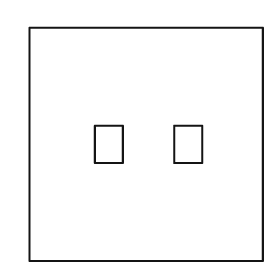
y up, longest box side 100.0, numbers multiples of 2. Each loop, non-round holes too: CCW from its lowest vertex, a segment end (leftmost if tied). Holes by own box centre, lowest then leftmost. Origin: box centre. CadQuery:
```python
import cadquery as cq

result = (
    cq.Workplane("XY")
    .moveTo(-50.0, -50.0)
    .lineTo(50.0, -50.0)
    .lineTo(50.0, 50.0)
    .lineTo(-50.0, 50.0)
    .close()
    .moveTo(-22.0, -8.0)
    .lineTo(-10.0, -8.0)
    .lineTo(-10.0, 8.0)
    .lineTo(-22.0, 8.0)
    .close()
    .moveTo(12.0, -8.0)
    .lineTo(24.0, -8.0)
    .lineTo(24.0, 8.0)
    .lineTo(12.0, 8.0)
    .close()
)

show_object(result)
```